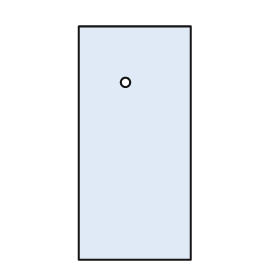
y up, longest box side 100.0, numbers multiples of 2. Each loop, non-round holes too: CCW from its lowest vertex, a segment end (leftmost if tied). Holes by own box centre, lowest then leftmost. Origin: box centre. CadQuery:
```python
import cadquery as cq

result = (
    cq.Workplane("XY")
    .moveTo(-24.0, -50.0)
    .lineTo(24.0, -50.0)
    .lineTo(24.0, 50.0)
    .lineTo(-24.0, 50.0)
    .close()
    .moveTo(-4.0, 26.0)
    .circle(2.0)
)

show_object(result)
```